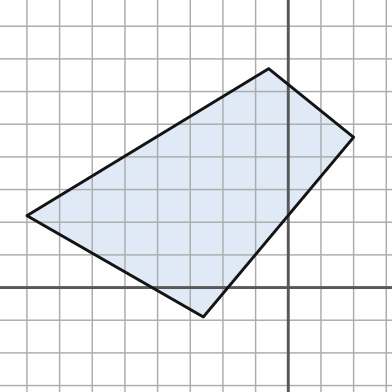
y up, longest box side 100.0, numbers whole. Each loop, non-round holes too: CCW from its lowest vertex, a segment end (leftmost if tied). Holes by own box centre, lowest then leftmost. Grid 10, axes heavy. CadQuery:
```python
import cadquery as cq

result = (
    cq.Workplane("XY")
    .moveTo(-26.0, -9.0)
    .lineTo(20.0, 46.0)
    .lineTo(-6.0, 67.0)
    .lineTo(-80.0, 22.0)
    .close()
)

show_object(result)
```